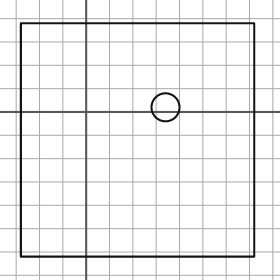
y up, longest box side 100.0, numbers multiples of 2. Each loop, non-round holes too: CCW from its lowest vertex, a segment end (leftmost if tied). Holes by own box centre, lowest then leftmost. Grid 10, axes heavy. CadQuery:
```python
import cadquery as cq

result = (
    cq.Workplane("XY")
    .moveTo(-28.0, -62.0)
    .lineTo(72.0, -62.0)
    .lineTo(72.0, 38.0)
    .lineTo(-28.0, 38.0)
    .close()
    .moveTo(34.0, 2.0)
    .circle(6.0)
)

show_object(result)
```